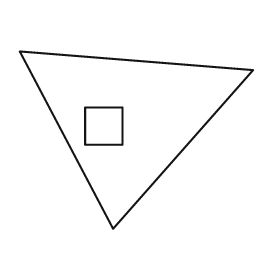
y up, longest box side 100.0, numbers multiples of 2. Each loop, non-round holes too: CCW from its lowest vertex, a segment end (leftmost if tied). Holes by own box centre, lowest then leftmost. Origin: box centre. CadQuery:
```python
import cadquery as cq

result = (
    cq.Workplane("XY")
    .moveTo(-10.0, -38.0)
    .lineTo(50.0, 30.0)
    .lineTo(-50.0, 38.0)
    .close()
    .moveTo(-22.0, -2.0)
    .lineTo(-6.0, -2.0)
    .lineTo(-6.0, 14.0)
    .lineTo(-22.0, 14.0)
    .close()
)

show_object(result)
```